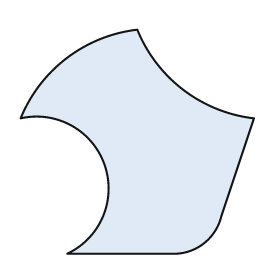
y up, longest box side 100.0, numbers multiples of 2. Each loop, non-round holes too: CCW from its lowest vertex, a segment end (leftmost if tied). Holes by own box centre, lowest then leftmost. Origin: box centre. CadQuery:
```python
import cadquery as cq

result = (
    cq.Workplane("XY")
    .moveTo(-30.0, -48.0)
    .lineTo(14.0, -48.0)
    .threePointArc((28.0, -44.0), (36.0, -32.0))
    .lineTo(50.0, 10.0)
    .threePointArc((20.0, 22.0), (0.0, 48.0))
    .threePointArc((-30.0, 36.0), (-50.0, 10.0))
    .threePointArc((-14.0, -10.0), (-30.0, -48.0))
    .close()
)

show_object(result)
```